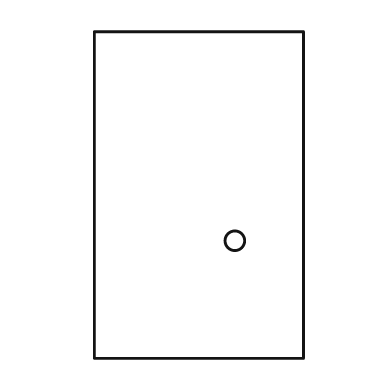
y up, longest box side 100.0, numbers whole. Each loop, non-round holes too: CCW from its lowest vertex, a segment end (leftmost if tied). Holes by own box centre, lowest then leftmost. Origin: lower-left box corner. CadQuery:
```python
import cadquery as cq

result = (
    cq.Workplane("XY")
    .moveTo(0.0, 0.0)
    .lineTo(64.0, 0.0)
    .lineTo(64.0, 100.0)
    .lineTo(0.0, 100.0)
    .close()
    .moveTo(43.0, 36.0)
    .circle(3.0)
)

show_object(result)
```